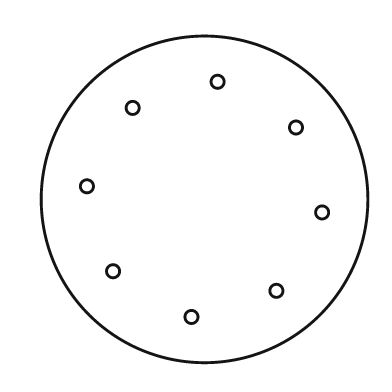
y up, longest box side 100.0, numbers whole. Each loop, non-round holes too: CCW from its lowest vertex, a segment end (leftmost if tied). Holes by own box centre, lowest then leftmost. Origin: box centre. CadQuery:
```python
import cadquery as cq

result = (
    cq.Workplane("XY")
    .moveTo(0.0, 0.0)
    .circle(50.0)
    .moveTo(-4.0, -36.0)
    .circle(2.0)
    .moveTo(22.0, -28.0)
    .circle(2.0)
    .moveTo(-28.0, -22.0)
    .circle(2.0)
    .moveTo(36.0, -4.0)
    .circle(2.0)
    .moveTo(-36.0, 4.0)
    .circle(2.0)
    .moveTo(28.0, 22.0)
    .circle(2.0)
    .moveTo(-22.0, 28.0)
    .circle(2.0)
    .moveTo(4.0, 36.0)
    .circle(2.0)
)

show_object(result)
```